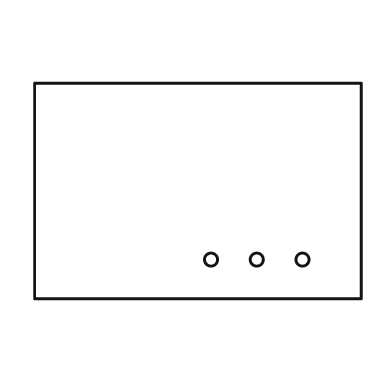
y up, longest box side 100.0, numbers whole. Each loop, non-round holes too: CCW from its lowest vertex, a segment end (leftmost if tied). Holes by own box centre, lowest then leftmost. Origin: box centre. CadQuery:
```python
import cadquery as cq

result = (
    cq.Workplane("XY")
    .moveTo(-50.0, -33.0)
    .lineTo(50.0, -33.0)
    .lineTo(50.0, 33.0)
    .lineTo(-50.0, 33.0)
    .close()
    .moveTo(4.0, -21.0)
    .circle(2.0)
    .moveTo(18.0, -21.0)
    .circle(2.0)
    .moveTo(32.0, -21.0)
    .circle(2.0)
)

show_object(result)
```